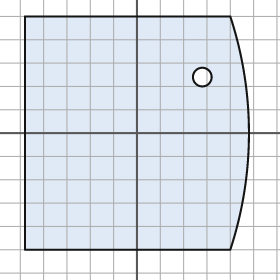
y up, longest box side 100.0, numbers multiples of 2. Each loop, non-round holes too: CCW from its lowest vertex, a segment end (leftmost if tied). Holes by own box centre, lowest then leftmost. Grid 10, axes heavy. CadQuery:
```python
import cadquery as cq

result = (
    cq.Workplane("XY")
    .moveTo(-48.0, -50.0)
    .lineTo(40.0, -50.0)
    .threePointArc((48.0, 0.0), (40.0, 50.0))
    .lineTo(-48.0, 50.0)
    .close()
    .moveTo(28.0, 24.0)
    .circle(4.0)
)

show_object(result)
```